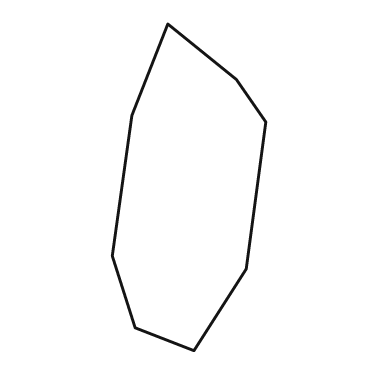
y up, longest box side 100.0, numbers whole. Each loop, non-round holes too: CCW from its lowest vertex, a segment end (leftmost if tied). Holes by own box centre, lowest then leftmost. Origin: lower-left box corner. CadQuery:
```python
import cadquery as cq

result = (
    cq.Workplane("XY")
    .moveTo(25.0, 0.0)
    .lineTo(41.0, 25.0)
    .lineTo(47.0, 70.0)
    .lineTo(38.0, 83.0)
    .lineTo(17.0, 100.0)
    .lineTo(6.0, 72.0)
    .lineTo(0.0, 29.0)
    .lineTo(7.0, 7.0)
    .close()
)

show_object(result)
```